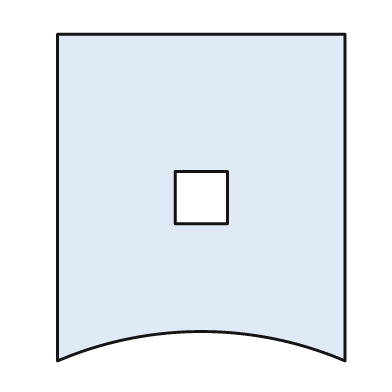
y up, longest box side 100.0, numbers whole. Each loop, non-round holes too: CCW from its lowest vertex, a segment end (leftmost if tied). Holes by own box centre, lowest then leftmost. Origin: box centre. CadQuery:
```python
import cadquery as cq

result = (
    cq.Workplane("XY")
    .moveTo(-44.0, -50.0)
    .threePointArc((0.0, -41.0), (44.0, -50.0))
    .lineTo(44.0, 50.0)
    .lineTo(-44.0, 50.0)
    .close()
    .moveTo(-8.0, -8.0)
    .lineTo(8.0, -8.0)
    .lineTo(8.0, 8.0)
    .lineTo(-8.0, 8.0)
    .close()
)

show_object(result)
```